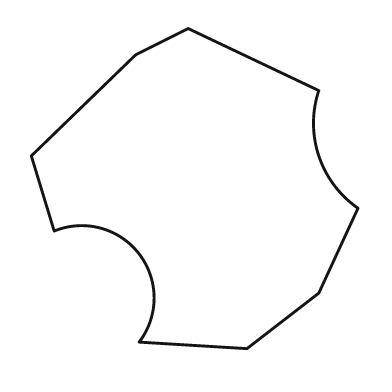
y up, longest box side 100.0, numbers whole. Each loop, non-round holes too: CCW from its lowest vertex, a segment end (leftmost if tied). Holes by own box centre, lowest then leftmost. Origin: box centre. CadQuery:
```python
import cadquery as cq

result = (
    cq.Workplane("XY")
    .moveTo(16.0, -49.0)
    .lineTo(38.0, -32.0)
    .lineTo(50.0, -6.0)
    .threePointArc((38.0, 10.0), (38.0, 30.0))
    .lineTo(-2.0, 49.0)
    .lineTo(-18.0, 41.0)
    .lineTo(-50.0, 10.0)
    .lineTo(-43.0, -13.0)
    .threePointArc((-17.0, -20.0), (-17.0, -47.0))
    .close()
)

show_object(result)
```